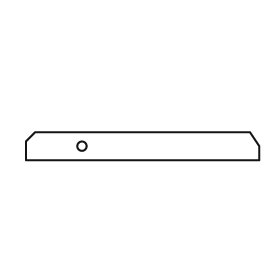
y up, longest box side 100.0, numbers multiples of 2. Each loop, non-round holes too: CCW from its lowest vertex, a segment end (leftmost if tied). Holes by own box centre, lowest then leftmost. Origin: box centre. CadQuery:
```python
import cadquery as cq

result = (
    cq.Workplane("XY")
    .moveTo(-50.0, -6.0)
    .lineTo(50.0, -6.0)
    .lineTo(50.0, 0.0)
    .lineTo(46.0, 6.0)
    .lineTo(-46.0, 6.0)
    .lineTo(-50.0, 2.0)
    .close()
    .moveTo(-26.0, 0.0)
    .circle(2.0)
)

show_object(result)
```